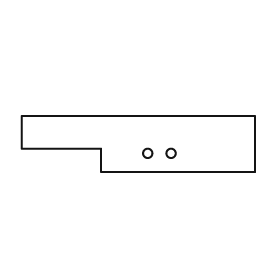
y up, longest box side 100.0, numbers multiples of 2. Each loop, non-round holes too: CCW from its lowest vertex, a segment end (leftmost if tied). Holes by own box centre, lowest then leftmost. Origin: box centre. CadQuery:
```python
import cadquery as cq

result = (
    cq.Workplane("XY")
    .moveTo(-16.0, -12.0)
    .lineTo(50.0, -12.0)
    .lineTo(50.0, 12.0)
    .lineTo(-50.0, 12.0)
    .lineTo(-50.0, -2.0)
    .lineTo(-16.0, -2.0)
    .close()
    .moveTo(4.0, -4.0)
    .circle(2.0)
    .moveTo(14.0, -4.0)
    .circle(2.0)
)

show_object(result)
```